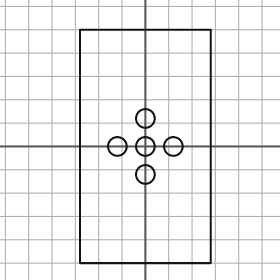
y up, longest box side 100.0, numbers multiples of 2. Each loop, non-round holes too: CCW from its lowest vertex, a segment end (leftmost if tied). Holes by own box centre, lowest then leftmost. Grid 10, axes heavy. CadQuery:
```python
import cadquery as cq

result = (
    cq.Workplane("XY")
    .moveTo(-28.0, -50.0)
    .lineTo(28.0, -50.0)
    .lineTo(28.0, 50.0)
    .lineTo(-28.0, 50.0)
    .close()
    .moveTo(0.0, -12.0)
    .circle(4.0)
    .moveTo(-12.0, 0.0)
    .circle(4.0)
    .moveTo(0.0, 0.0)
    .circle(4.0)
    .moveTo(12.0, 0.0)
    .circle(4.0)
    .moveTo(0.0, 12.0)
    .circle(4.0)
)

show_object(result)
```